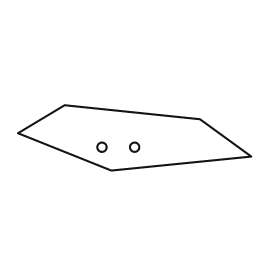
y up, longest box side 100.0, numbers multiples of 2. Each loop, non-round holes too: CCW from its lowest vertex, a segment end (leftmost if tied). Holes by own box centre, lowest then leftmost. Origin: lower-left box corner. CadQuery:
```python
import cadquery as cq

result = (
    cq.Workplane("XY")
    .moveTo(40.0, 0.0)
    .lineTo(100.0, 6.0)
    .lineTo(78.0, 22.0)
    .lineTo(20.0, 28.0)
    .lineTo(0.0, 16.0)
    .close()
    .moveTo(36.0, 10.0)
    .circle(2.0)
    .moveTo(50.0, 10.0)
    .circle(2.0)
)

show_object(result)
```